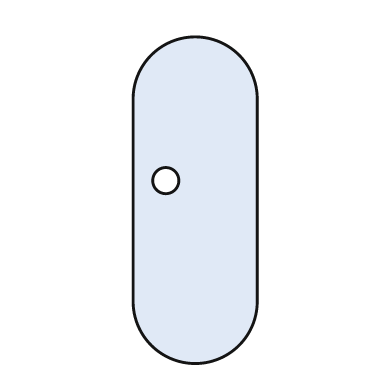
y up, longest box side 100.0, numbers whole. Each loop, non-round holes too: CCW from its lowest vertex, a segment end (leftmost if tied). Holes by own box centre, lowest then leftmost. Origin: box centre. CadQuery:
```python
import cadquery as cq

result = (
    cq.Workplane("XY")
    .moveTo(-19.0, -31.0)
    .threePointArc((0.0, -50.0), (19.0, -31.0))
    .lineTo(19.0, 31.0)
    .threePointArc((0.0, 50.0), (-19.0, 31.0))
    .close()
    .moveTo(-9.0, 6.0)
    .circle(4.0)
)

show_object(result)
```